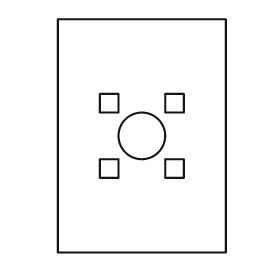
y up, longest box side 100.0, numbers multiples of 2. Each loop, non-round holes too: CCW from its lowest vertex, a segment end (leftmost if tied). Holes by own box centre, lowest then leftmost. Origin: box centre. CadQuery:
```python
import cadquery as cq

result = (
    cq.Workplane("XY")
    .moveTo(-36.0, -50.0)
    .lineTo(36.0, -50.0)
    .lineTo(36.0, 50.0)
    .lineTo(-36.0, 50.0)
    .close()
    .moveTo(-18.0, -18.0)
    .lineTo(-10.0, -18.0)
    .lineTo(-10.0, -10.0)
    .lineTo(-18.0, -10.0)
    .close()
    .moveTo(10.0, -18.0)
    .lineTo(18.0, -18.0)
    .lineTo(18.0, -10.0)
    .lineTo(10.0, -10.0)
    .close()
    .moveTo(0.0, 0.0)
    .circle(10.0)
    .moveTo(-18.0, 10.0)
    .lineTo(-10.0, 10.0)
    .lineTo(-10.0, 18.0)
    .lineTo(-18.0, 18.0)
    .close()
    .moveTo(10.0, 10.0)
    .lineTo(18.0, 10.0)
    .lineTo(18.0, 18.0)
    .lineTo(10.0, 18.0)
    .close()
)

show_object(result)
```